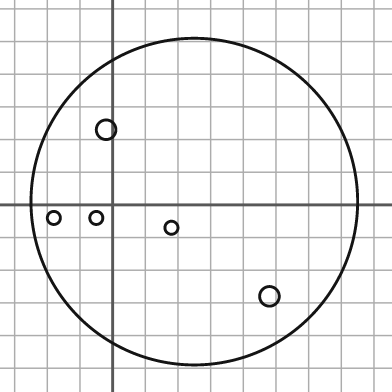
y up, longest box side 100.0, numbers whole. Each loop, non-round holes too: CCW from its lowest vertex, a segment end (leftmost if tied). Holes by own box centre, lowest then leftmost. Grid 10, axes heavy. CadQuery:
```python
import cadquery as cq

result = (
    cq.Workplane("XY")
    .moveTo(25.0, 1.0)
    .circle(50.0)
    .moveTo(48.0, -28.0)
    .circle(3.0)
    .moveTo(18.0, -7.0)
    .circle(2.0)
    .moveTo(-18.0, -4.0)
    .circle(2.0)
    .moveTo(-5.0, -4.0)
    .circle(2.0)
    .moveTo(-2.0, 23.0)
    .circle(3.0)
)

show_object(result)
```